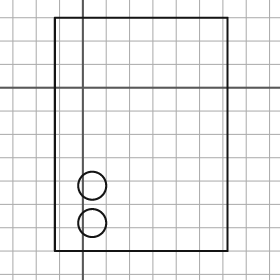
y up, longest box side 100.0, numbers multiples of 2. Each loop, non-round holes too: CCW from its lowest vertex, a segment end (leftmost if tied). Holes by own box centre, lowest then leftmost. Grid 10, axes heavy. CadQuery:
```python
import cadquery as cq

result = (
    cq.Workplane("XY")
    .moveTo(-12.0, -70.0)
    .lineTo(62.0, -70.0)
    .lineTo(62.0, 30.0)
    .lineTo(-12.0, 30.0)
    .close()
    .moveTo(4.0, -58.0)
    .circle(6.0)
    .moveTo(4.0, -42.0)
    .circle(6.0)
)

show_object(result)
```